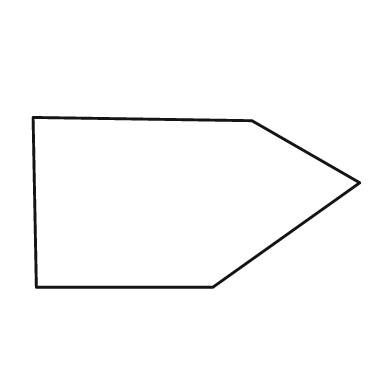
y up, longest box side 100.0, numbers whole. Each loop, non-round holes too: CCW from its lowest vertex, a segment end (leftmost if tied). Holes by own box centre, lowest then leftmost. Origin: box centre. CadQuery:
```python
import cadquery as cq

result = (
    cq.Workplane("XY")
    .moveTo(-49.0, -26.0)
    .lineTo(5.0, -26.0)
    .lineTo(50.0, 6.0)
    .lineTo(17.0, 25.0)
    .lineTo(-50.0, 26.0)
    .close()
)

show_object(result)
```